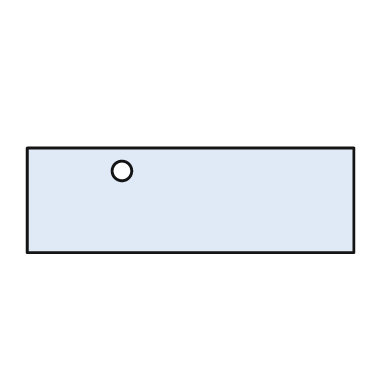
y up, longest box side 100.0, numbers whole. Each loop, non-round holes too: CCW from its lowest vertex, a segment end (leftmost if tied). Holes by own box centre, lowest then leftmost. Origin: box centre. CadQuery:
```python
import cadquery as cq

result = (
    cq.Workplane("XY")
    .moveTo(-50.0, -16.0)
    .lineTo(50.0, -16.0)
    .lineTo(50.0, 16.0)
    .lineTo(-50.0, 16.0)
    .close()
    .moveTo(-21.0, 9.0)
    .circle(3.0)
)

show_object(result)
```